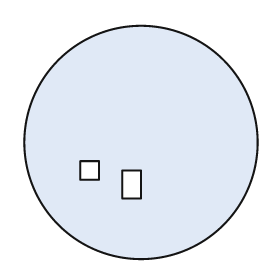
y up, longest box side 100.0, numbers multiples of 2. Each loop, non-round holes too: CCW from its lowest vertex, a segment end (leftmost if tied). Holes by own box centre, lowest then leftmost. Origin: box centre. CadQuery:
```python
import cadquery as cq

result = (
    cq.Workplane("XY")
    .moveTo(0.0, 0.0)
    .circle(50.0)
    .moveTo(-8.0, -24.0)
    .lineTo(0.0, -24.0)
    .lineTo(0.0, -12.0)
    .lineTo(-8.0, -12.0)
    .close()
    .moveTo(-26.0, -16.0)
    .lineTo(-18.0, -16.0)
    .lineTo(-18.0, -8.0)
    .lineTo(-26.0, -8.0)
    .close()
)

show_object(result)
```